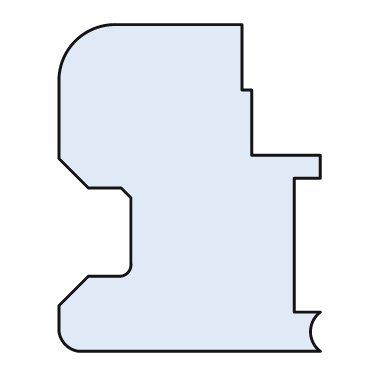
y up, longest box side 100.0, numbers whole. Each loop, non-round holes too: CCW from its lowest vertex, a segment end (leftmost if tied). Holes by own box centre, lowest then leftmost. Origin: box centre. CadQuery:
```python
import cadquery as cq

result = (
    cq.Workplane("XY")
    .moveTo(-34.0, -50.0)
    .lineTo(40.0, -50.0)
    .threePointArc((37.0, -44.0), (40.0, -38.0))
    .lineTo(32.0, -38.0)
    .lineTo(32.0, 3.0)
    .lineTo(40.0, 3.0)
    .lineTo(40.0, 10.0)
    .lineTo(19.0, 10.0)
    .lineTo(19.0, 30.0)
    .lineTo(16.0, 30.0)
    .lineTo(16.0, 50.0)
    .lineTo(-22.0, 50.0)
    .threePointArc((-35.0, 45.0), (-40.0, 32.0))
    .lineTo(-40.0, 9.0)
    .lineTo(-31.0, 0.0)
    .lineTo(-21.0, 0.0)
    .lineTo(-18.0, -3.0)
    .lineTo(-18.0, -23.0)
    .threePointArc((-19.0, -26.0), (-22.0, -27.0))
    .lineTo(-31.0, -27.0)
    .lineTo(-40.0, -36.0)
    .lineTo(-40.0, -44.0)
    .threePointArc((-38.0, -48.0), (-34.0, -50.0))
    .close()
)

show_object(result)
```